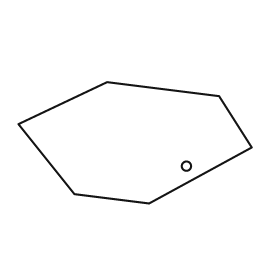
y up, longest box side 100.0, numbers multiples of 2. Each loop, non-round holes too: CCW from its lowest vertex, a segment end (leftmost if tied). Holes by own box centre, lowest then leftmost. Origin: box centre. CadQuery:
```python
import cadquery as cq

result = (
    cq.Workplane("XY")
    .moveTo(6.0, -26.0)
    .lineTo(50.0, -2.0)
    .lineTo(36.0, 20.0)
    .lineTo(-12.0, 26.0)
    .lineTo(-50.0, 8.0)
    .lineTo(-26.0, -22.0)
    .close()
    .moveTo(22.0, -10.0)
    .circle(2.0)
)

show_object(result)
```